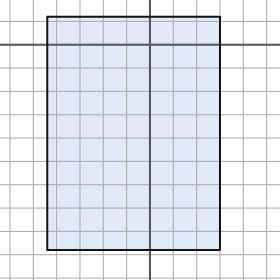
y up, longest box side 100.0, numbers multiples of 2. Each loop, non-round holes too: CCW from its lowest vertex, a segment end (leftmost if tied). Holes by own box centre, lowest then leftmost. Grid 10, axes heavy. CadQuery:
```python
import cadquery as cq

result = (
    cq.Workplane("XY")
    .moveTo(-44.0, -88.0)
    .lineTo(30.0, -88.0)
    .lineTo(30.0, 12.0)
    .lineTo(-44.0, 12.0)
    .close()
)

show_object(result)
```